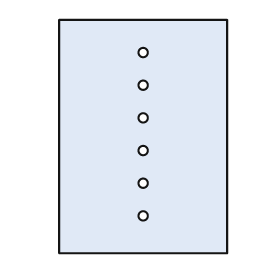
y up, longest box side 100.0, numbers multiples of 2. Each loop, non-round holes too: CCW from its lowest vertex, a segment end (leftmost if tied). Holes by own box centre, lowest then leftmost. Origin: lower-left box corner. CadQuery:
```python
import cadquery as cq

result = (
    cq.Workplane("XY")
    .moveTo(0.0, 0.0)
    .lineTo(72.0, 0.0)
    .lineTo(72.0, 100.0)
    .lineTo(0.0, 100.0)
    .close()
    .moveTo(36.0, 16.0)
    .circle(2.0)
    .moveTo(36.0, 30.0)
    .circle(2.0)
    .moveTo(36.0, 44.0)
    .circle(2.0)
    .moveTo(36.0, 58.0)
    .circle(2.0)
    .moveTo(36.0, 72.0)
    .circle(2.0)
    .moveTo(36.0, 86.0)
    .circle(2.0)
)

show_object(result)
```